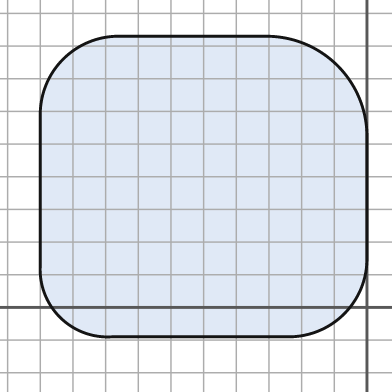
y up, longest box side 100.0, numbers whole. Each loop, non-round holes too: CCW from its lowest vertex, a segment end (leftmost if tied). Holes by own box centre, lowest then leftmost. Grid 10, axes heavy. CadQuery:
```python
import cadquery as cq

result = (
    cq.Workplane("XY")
    .moveTo(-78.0, -9.0)
    .lineTo(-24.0, -9.0)
    .threePointArc((-7.0, -2.0), (0.0, 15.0))
    .lineTo(0.0, 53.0)
    .threePointArc((-9.0, 74.0), (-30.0, 83.0))
    .lineTo(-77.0, 83.0)
    .threePointArc((-93.0, 76.0), (-100.0, 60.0))
    .lineTo(-100.0, 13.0)
    .threePointArc((-94.0, -3.0), (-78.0, -9.0))
    .close()
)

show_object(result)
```